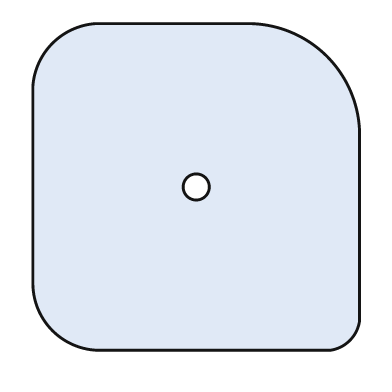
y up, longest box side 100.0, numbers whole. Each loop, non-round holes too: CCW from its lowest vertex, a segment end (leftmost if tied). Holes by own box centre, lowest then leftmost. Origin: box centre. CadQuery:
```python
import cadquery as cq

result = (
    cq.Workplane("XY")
    .moveTo(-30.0, -50.0)
    .lineTo(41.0, -50.0)
    .threePointArc((47.0, -47.0), (50.0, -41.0))
    .lineTo(50.0, 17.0)
    .threePointArc((40.0, 40.0), (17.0, 50.0))
    .lineTo(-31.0, 50.0)
    .threePointArc((-44.0, 44.0), (-50.0, 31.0))
    .lineTo(-50.0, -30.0)
    .threePointArc((-44.0, -44.0), (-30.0, -50.0))
    .close()
    .moveTo(0.0, 0.0)
    .circle(4.0)
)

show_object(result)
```